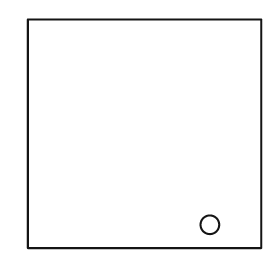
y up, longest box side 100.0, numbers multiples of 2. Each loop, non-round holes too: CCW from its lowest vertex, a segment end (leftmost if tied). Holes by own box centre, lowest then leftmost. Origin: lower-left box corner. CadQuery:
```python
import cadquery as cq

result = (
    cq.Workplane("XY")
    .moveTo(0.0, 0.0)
    .lineTo(100.0, 0.0)
    .lineTo(100.0, 98.0)
    .lineTo(0.0, 98.0)
    .close()
    .moveTo(78.0, 10.0)
    .circle(4.0)
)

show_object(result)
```